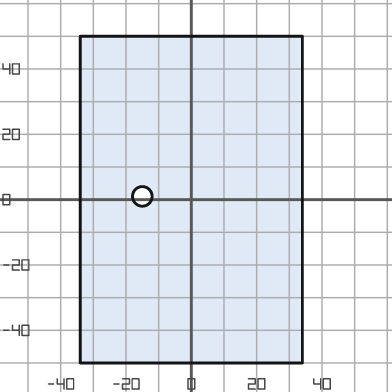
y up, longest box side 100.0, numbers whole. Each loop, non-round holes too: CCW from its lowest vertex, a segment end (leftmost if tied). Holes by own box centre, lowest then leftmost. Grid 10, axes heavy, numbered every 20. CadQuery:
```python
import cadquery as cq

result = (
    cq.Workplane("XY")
    .moveTo(-34.0, -50.0)
    .lineTo(34.0, -50.0)
    .lineTo(34.0, 50.0)
    .lineTo(-34.0, 50.0)
    .close()
    .moveTo(-15.0, 1.0)
    .circle(3.0)
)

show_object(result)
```